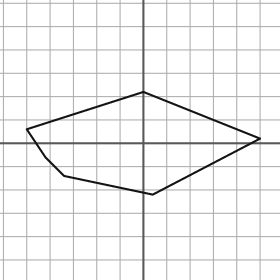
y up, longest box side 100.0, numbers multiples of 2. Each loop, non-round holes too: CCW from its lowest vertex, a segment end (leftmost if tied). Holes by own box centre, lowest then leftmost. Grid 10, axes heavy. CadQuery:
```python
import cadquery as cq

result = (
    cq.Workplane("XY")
    .moveTo(4.0, -22.0)
    .lineTo(50.0, 2.0)
    .lineTo(0.0, 22.0)
    .lineTo(-50.0, 6.0)
    .lineTo(-42.0, -6.0)
    .lineTo(-34.0, -14.0)
    .close()
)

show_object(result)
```